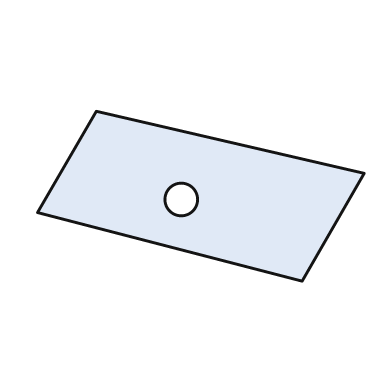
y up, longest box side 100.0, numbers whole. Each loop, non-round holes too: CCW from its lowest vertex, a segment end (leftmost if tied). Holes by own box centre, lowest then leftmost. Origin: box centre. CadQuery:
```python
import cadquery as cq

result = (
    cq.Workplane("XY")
    .moveTo(31.0, -26.0)
    .lineTo(50.0, 7.0)
    .lineTo(-32.0, 26.0)
    .lineTo(-50.0, -5.0)
    .close()
    .moveTo(-6.0, -1.0)
    .circle(5.0)
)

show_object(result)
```